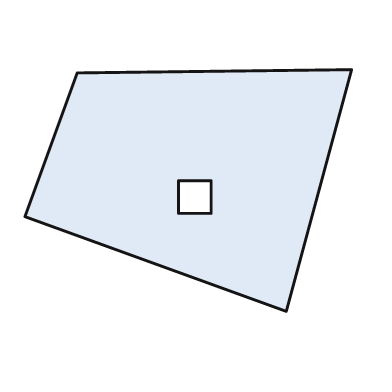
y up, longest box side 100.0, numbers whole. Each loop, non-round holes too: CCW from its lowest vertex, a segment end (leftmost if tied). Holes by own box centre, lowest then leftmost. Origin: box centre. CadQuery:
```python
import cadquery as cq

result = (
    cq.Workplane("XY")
    .moveTo(30.0, -37.0)
    .lineTo(50.0, 37.0)
    .lineTo(-34.0, 36.0)
    .lineTo(-50.0, -8.0)
    .close()
    .moveTo(-3.0, -7.0)
    .lineTo(7.0, -7.0)
    .lineTo(7.0, 3.0)
    .lineTo(-3.0, 3.0)
    .close()
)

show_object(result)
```